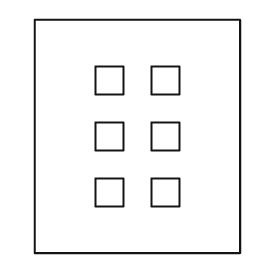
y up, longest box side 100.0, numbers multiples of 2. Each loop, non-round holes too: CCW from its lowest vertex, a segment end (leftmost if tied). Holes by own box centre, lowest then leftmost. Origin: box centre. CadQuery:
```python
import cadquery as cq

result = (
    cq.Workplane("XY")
    .moveTo(-44.0, -50.0)
    .lineTo(44.0, -50.0)
    .lineTo(44.0, 50.0)
    .lineTo(-44.0, 50.0)
    .close()
    .moveTo(-18.0, -30.0)
    .lineTo(-6.0, -30.0)
    .lineTo(-6.0, -18.0)
    .lineTo(-18.0, -18.0)
    .close()
    .moveTo(6.0, -30.0)
    .lineTo(18.0, -30.0)
    .lineTo(18.0, -18.0)
    .lineTo(6.0, -18.0)
    .close()
    .moveTo(-18.0, -6.0)
    .lineTo(-6.0, -6.0)
    .lineTo(-6.0, 6.0)
    .lineTo(-18.0, 6.0)
    .close()
    .moveTo(6.0, -6.0)
    .lineTo(18.0, -6.0)
    .lineTo(18.0, 6.0)
    .lineTo(6.0, 6.0)
    .close()
    .moveTo(-18.0, 18.0)
    .lineTo(-6.0, 18.0)
    .lineTo(-6.0, 30.0)
    .lineTo(-18.0, 30.0)
    .close()
    .moveTo(6.0, 18.0)
    .lineTo(18.0, 18.0)
    .lineTo(18.0, 30.0)
    .lineTo(6.0, 30.0)
    .close()
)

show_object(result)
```